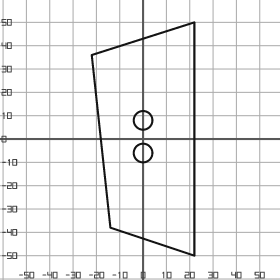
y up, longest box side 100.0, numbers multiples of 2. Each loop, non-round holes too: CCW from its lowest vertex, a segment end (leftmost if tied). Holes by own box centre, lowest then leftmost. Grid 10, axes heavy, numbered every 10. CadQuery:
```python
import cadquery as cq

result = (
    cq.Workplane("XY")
    .moveTo(22.0, -50.0)
    .lineTo(22.0, 50.0)
    .lineTo(-22.0, 36.0)
    .lineTo(-14.0, -38.0)
    .close()
    .moveTo(0.0, -6.0)
    .circle(4.0)
    .moveTo(0.0, 8.0)
    .circle(4.0)
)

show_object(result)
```